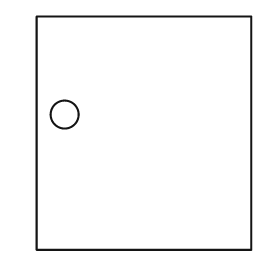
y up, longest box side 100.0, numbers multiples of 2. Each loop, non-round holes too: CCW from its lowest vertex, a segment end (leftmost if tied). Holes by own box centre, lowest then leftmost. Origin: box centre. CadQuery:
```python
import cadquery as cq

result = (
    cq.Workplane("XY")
    .moveTo(-46.0, -50.0)
    .lineTo(46.0, -50.0)
    .lineTo(46.0, 50.0)
    .lineTo(-46.0, 50.0)
    .close()
    .moveTo(-34.0, 8.0)
    .circle(6.0)
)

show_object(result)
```